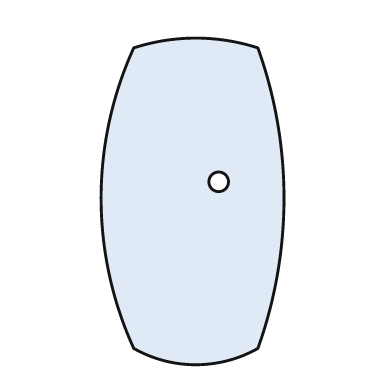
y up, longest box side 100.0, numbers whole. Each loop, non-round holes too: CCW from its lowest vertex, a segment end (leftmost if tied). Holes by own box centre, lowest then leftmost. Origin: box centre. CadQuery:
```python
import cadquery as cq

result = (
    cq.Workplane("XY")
    .moveTo(-18.0, -45.0)
    .threePointArc((1.0, -50.0), (20.0, -45.0))
    .threePointArc((28.0, 1.0), (20.0, 47.0))
    .threePointArc((1.0, 50.0), (-18.0, 47.0))
    .threePointArc((-28.0, 1.0), (-18.0, -45.0))
    .close()
    .moveTo(8.0, 6.0)
    .circle(3.0)
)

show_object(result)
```